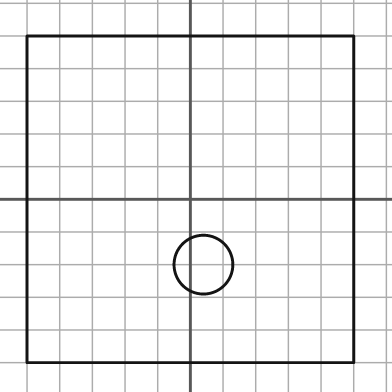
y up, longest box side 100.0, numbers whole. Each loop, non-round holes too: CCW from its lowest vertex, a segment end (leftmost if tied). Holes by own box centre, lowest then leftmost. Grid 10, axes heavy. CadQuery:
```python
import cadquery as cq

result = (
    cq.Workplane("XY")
    .moveTo(-50.0, -50.0)
    .lineTo(50.0, -50.0)
    .lineTo(50.0, 50.0)
    .lineTo(-50.0, 50.0)
    .close()
    .moveTo(4.0, -20.0)
    .circle(9.0)
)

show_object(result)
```